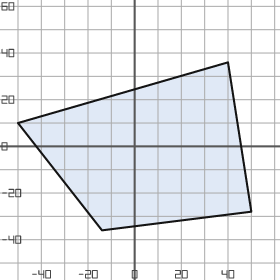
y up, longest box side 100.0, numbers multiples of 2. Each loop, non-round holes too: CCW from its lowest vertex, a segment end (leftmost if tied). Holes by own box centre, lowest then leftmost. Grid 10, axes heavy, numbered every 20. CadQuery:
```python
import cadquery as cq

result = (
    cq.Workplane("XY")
    .moveTo(-14.0, -36.0)
    .lineTo(50.0, -28.0)
    .lineTo(40.0, 36.0)
    .lineTo(-50.0, 10.0)
    .close()
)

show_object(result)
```